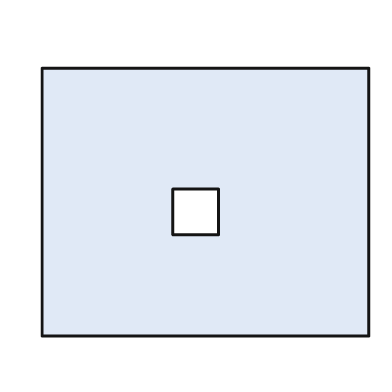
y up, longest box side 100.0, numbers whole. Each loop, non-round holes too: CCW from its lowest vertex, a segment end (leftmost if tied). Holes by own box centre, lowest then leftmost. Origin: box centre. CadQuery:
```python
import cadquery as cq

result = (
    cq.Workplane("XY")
    .moveTo(-50.0, -41.0)
    .lineTo(50.0, -41.0)
    .lineTo(50.0, 41.0)
    .lineTo(-50.0, 41.0)
    .close()
    .moveTo(-10.0, -10.0)
    .lineTo(4.0, -10.0)
    .lineTo(4.0, 4.0)
    .lineTo(-10.0, 4.0)
    .close()
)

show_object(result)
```